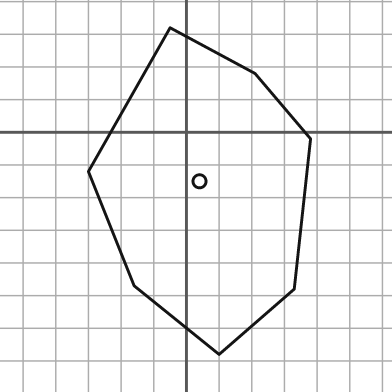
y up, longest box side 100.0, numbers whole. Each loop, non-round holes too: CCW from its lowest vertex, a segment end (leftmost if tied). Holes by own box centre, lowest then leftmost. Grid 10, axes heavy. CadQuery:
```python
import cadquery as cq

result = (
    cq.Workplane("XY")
    .moveTo(10.0, -68.0)
    .lineTo(33.0, -48.0)
    .lineTo(38.0, -2.0)
    .lineTo(21.0, 18.0)
    .lineTo(-5.0, 32.0)
    .lineTo(-30.0, -12.0)
    .lineTo(-16.0, -47.0)
    .close()
    .moveTo(4.0, -15.0)
    .circle(2.0)
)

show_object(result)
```